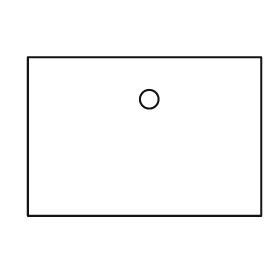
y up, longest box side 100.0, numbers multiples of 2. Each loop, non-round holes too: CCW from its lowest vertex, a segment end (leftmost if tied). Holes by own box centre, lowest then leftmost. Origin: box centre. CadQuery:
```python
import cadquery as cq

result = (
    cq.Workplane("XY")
    .moveTo(-50.0, -34.0)
    .lineTo(50.0, -34.0)
    .lineTo(50.0, 34.0)
    .lineTo(-50.0, 34.0)
    .close()
    .moveTo(2.0, 16.0)
    .circle(4.0)
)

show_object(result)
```